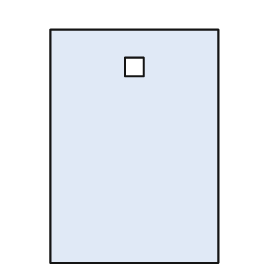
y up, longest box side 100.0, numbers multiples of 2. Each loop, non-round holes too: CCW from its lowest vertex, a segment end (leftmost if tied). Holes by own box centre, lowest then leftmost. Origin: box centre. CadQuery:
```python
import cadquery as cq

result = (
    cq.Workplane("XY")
    .moveTo(-36.0, -50.0)
    .lineTo(36.0, -50.0)
    .lineTo(36.0, 50.0)
    .lineTo(-36.0, 50.0)
    .close()
    .moveTo(-4.0, 30.0)
    .lineTo(4.0, 30.0)
    .lineTo(4.0, 38.0)
    .lineTo(-4.0, 38.0)
    .close()
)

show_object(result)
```